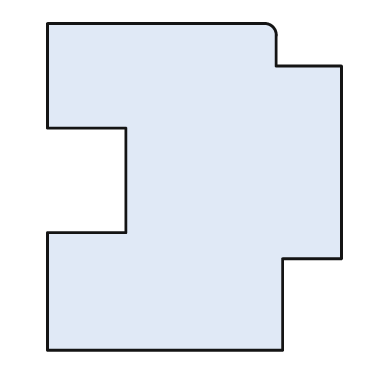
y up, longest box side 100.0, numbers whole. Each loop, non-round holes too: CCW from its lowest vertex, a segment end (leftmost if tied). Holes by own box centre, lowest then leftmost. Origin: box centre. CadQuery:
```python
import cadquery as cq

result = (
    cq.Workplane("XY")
    .moveTo(-45.0, -50.0)
    .lineTo(27.0, -50.0)
    .lineTo(27.0, -22.0)
    .lineTo(45.0, -22.0)
    .lineTo(45.0, 37.0)
    .lineTo(25.0, 37.0)
    .lineTo(25.0, 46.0)
    .threePointArc((24.0, 49.0), (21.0, 50.0))
    .lineTo(-45.0, 50.0)
    .lineTo(-45.0, 18.0)
    .lineTo(-21.0, 18.0)
    .lineTo(-21.0, -14.0)
    .lineTo(-45.0, -14.0)
    .close()
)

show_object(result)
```